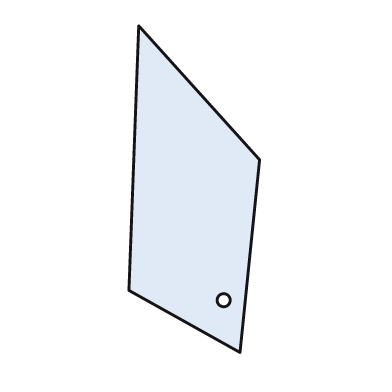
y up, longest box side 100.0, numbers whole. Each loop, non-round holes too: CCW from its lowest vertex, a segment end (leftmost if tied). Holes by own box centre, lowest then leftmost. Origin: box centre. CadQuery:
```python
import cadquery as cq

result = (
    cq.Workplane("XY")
    .moveTo(14.0, -50.0)
    .lineTo(20.0, 9.0)
    .lineTo(-17.0, 50.0)
    .lineTo(-20.0, -31.0)
    .close()
    .moveTo(9.0, -34.0)
    .circle(2.0)
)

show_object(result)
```